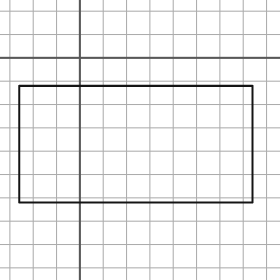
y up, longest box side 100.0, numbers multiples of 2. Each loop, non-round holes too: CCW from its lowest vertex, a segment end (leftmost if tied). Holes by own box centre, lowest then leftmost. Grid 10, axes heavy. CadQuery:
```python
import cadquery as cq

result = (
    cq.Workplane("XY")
    .moveTo(-26.0, -62.0)
    .lineTo(74.0, -62.0)
    .lineTo(74.0, -12.0)
    .lineTo(-26.0, -12.0)
    .close()
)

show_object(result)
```